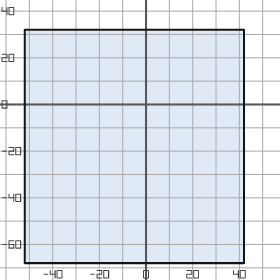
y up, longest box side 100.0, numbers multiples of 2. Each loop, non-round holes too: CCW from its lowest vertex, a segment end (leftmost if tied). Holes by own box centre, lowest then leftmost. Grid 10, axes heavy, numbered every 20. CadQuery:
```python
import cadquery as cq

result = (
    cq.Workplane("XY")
    .moveTo(-52.0, -68.0)
    .lineTo(42.0, -68.0)
    .lineTo(42.0, 32.0)
    .lineTo(-52.0, 32.0)
    .close()
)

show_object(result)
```